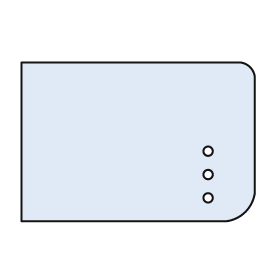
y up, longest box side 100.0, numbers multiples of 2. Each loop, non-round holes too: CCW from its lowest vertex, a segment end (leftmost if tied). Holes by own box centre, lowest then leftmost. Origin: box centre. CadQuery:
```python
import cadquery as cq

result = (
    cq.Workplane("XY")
    .moveTo(-50.0, -34.0)
    .lineTo(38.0, -34.0)
    .threePointArc((46.0, -30.0), (50.0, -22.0))
    .lineTo(50.0, 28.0)
    .threePointArc((48.0, 32.0), (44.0, 34.0))
    .lineTo(-50.0, 34.0)
    .close()
    .moveTo(30.0, -24.0)
    .circle(2.0)
    .moveTo(30.0, -14.0)
    .circle(2.0)
    .moveTo(30.0, -4.0)
    .circle(2.0)
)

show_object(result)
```